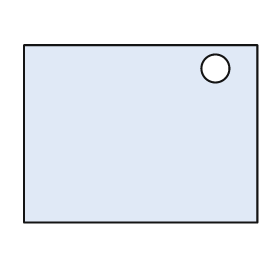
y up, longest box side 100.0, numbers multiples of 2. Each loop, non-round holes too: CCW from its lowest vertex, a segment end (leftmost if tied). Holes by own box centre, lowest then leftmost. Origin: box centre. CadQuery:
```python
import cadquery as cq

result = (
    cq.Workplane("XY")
    .moveTo(-50.0, -38.0)
    .lineTo(50.0, -38.0)
    .lineTo(50.0, 38.0)
    .lineTo(-50.0, 38.0)
    .close()
    .moveTo(32.0, 28.0)
    .circle(6.0)
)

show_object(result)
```